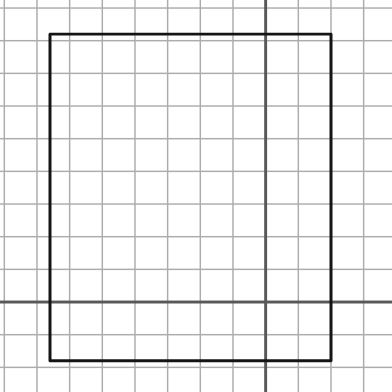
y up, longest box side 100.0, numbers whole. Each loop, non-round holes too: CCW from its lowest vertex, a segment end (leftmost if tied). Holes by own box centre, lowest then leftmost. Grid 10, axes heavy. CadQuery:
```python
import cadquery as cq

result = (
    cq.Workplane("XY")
    .moveTo(-66.0, -18.0)
    .lineTo(20.0, -18.0)
    .lineTo(20.0, 82.0)
    .lineTo(-66.0, 82.0)
    .close()
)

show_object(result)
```